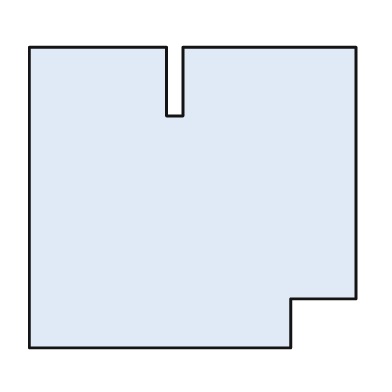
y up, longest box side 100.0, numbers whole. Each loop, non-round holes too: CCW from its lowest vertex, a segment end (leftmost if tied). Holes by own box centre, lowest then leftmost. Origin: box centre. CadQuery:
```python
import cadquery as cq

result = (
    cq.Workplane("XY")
    .moveTo(-50.0, -46.0)
    .lineTo(30.0, -46.0)
    .lineTo(30.0, -31.0)
    .lineTo(50.0, -31.0)
    .lineTo(50.0, 46.0)
    .lineTo(-3.0, 46.0)
    .lineTo(-3.0, 25.0)
    .lineTo(-8.0, 25.0)
    .lineTo(-8.0, 46.0)
    .lineTo(-50.0, 46.0)
    .close()
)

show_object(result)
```